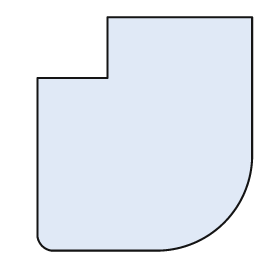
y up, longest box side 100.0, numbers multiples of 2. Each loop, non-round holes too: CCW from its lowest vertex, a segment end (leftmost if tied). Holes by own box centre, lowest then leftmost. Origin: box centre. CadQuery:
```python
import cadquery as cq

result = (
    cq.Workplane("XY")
    .moveTo(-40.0, -50.0)
    .lineTo(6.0, -50.0)
    .threePointArc((34.0, -38.0), (46.0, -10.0))
    .lineTo(46.0, 50.0)
    .lineTo(-16.0, 50.0)
    .lineTo(-16.0, 24.0)
    .lineTo(-46.0, 24.0)
    .lineTo(-46.0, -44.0)
    .threePointArc((-44.0, -48.0), (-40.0, -50.0))
    .close()
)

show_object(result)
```